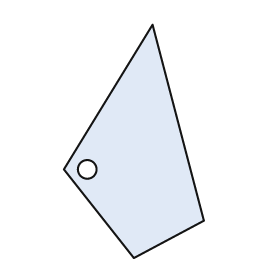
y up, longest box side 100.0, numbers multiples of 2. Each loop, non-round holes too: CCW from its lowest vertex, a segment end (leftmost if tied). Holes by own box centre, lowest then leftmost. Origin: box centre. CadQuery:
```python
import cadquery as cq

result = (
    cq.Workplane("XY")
    .moveTo(0.0, -50.0)
    .lineTo(30.0, -34.0)
    .lineTo(8.0, 50.0)
    .lineTo(-30.0, -12.0)
    .close()
    .moveTo(-20.0, -12.0)
    .circle(4.0)
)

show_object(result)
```